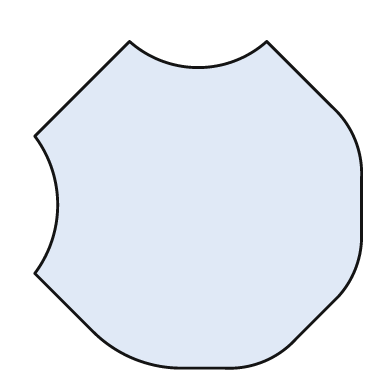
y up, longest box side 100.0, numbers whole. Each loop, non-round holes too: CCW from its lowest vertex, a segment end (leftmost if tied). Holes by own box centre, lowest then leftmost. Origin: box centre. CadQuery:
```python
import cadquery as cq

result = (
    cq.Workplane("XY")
    .moveTo(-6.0, -50.0)
    .lineTo(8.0, -50.0)
    .threePointArc((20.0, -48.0), (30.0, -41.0))
    .lineTo(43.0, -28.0)
    .threePointArc((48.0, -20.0), (50.0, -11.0))
    .lineTo(50.0, 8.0)
    .threePointArc((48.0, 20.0), (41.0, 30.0))
    .lineTo(21.0, 50.0)
    .threePointArc((0.0, 42.0), (-21.0, 50.0))
    .lineTo(-50.0, 21.0)
    .threePointArc((-43.0, 0.0), (-50.0, -21.0))
    .lineTo(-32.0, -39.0)
    .threePointArc((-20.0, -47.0), (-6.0, -50.0))
    .close()
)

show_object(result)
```